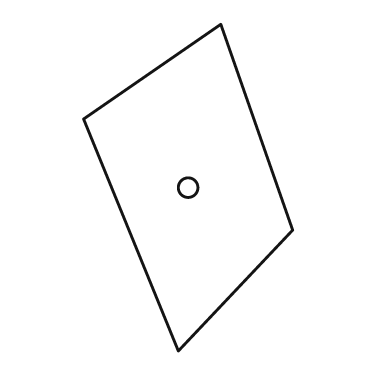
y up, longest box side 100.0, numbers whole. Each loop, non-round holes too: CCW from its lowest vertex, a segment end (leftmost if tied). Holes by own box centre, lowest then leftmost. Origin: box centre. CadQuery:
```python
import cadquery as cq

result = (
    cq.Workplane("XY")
    .moveTo(-3.0, -50.0)
    .lineTo(32.0, -13.0)
    .lineTo(10.0, 50.0)
    .lineTo(-32.0, 21.0)
    .close()
    .moveTo(0.0, 0.0)
    .circle(3.0)
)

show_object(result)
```